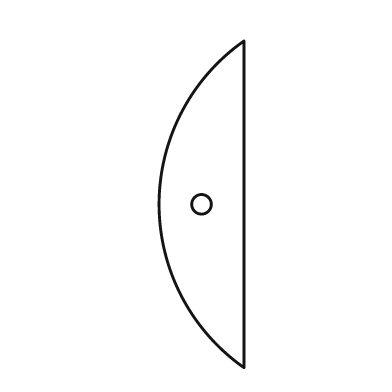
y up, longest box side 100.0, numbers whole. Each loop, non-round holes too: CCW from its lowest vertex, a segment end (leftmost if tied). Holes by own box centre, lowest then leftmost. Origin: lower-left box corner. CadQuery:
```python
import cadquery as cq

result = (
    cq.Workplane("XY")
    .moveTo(26.0, 0.0)
    .lineTo(26.0, 100.0)
    .threePointArc((0.0, 50.0), (26.0, 0.0))
    .close()
    .moveTo(13.0, 50.0)
    .circle(3.0)
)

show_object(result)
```